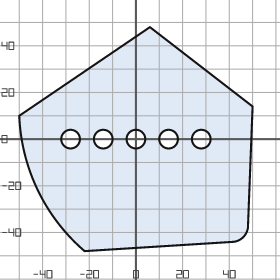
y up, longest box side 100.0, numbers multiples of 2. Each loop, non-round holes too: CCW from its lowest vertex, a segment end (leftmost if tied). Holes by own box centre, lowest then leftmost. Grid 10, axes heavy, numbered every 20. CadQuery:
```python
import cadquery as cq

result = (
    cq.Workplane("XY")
    .moveTo(-22.0, -48.0)
    .lineTo(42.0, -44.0)
    .threePointArc((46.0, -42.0), (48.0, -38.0))
    .lineTo(50.0, 14.0)
    .lineTo(6.0, 48.0)
    .lineTo(-50.0, 10.0)
    .threePointArc((-42.0, -22.0), (-22.0, -48.0))
    .close()
    .moveTo(-28.0, 0.0)
    .circle(4.0)
    .moveTo(-14.0, 0.0)
    .circle(4.0)
    .moveTo(0.0, 0.0)
    .circle(4.0)
    .moveTo(14.0, 0.0)
    .circle(4.0)
    .moveTo(28.0, 0.0)
    .circle(4.0)
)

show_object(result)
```